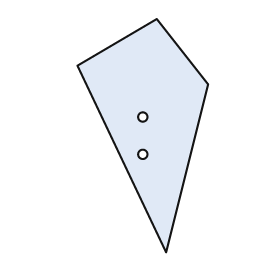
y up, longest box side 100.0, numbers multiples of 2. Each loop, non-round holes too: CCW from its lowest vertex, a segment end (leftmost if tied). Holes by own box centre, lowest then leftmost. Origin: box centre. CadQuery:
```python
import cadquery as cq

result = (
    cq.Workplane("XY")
    .moveTo(10.0, -50.0)
    .lineTo(28.0, 22.0)
    .lineTo(6.0, 50.0)
    .lineTo(-28.0, 30.0)
    .close()
    .moveTo(0.0, -8.0)
    .circle(2.0)
    .moveTo(0.0, 8.0)
    .circle(2.0)
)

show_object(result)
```